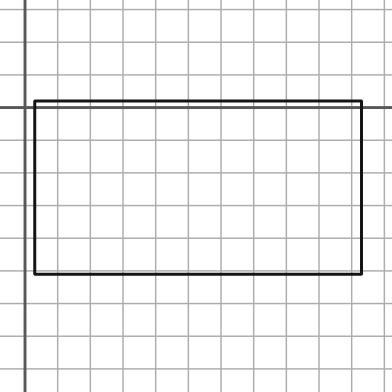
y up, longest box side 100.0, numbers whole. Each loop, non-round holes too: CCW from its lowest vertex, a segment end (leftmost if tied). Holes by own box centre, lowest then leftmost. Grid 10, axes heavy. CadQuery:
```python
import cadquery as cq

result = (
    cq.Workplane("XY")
    .moveTo(3.0, -51.0)
    .lineTo(103.0, -51.0)
    .lineTo(103.0, 2.0)
    .lineTo(3.0, 2.0)
    .close()
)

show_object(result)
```